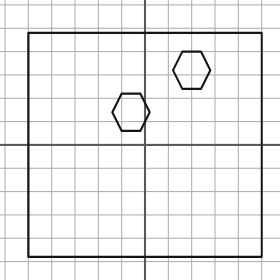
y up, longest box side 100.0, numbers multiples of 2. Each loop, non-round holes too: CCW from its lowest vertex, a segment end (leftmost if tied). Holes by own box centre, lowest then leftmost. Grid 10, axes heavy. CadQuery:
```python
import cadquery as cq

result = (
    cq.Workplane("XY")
    .moveTo(-50.0, -48.0)
    .lineTo(50.0, -48.0)
    .lineTo(50.0, 48.0)
    .lineTo(-50.0, 48.0)
    .close()
    .moveTo(-10.0, 6.0)
    .lineTo(-2.0, 6.0)
    .lineTo(2.0, 14.0)
    .lineTo(-2.0, 22.0)
    .lineTo(-10.0, 22.0)
    .lineTo(-14.0, 14.0)
    .close()
    .moveTo(16.0, 24.0)
    .lineTo(24.0, 24.0)
    .lineTo(28.0, 32.0)
    .lineTo(24.0, 40.0)
    .lineTo(16.0, 40.0)
    .lineTo(12.0, 32.0)
    .close()
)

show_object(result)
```